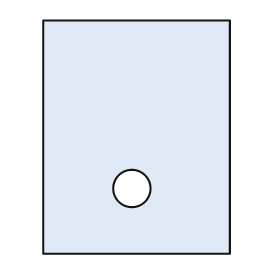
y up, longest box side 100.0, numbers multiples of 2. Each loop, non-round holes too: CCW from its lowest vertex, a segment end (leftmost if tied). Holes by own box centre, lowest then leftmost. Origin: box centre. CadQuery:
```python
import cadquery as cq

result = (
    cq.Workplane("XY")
    .moveTo(-40.0, -50.0)
    .lineTo(40.0, -50.0)
    .lineTo(40.0, 50.0)
    .lineTo(-40.0, 50.0)
    .close()
    .moveTo(-2.0, -22.0)
    .circle(8.0)
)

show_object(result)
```